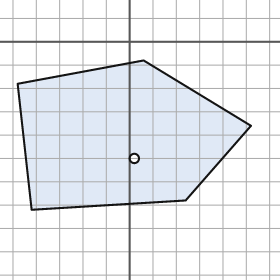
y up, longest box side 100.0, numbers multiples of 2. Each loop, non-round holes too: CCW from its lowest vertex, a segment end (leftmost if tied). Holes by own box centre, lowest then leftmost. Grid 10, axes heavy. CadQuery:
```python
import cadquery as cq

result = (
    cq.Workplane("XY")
    .moveTo(-42.0, -72.0)
    .lineTo(24.0, -68.0)
    .lineTo(52.0, -36.0)
    .lineTo(6.0, -8.0)
    .lineTo(-48.0, -18.0)
    .close()
    .moveTo(2.0, -50.0)
    .circle(2.0)
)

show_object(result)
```